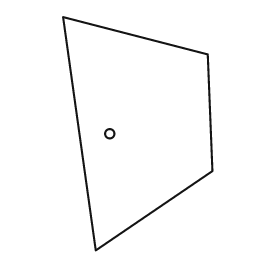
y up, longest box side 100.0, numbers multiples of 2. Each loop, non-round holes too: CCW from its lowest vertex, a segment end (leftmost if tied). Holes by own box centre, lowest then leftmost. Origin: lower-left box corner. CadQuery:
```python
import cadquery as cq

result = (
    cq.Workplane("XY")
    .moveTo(14.0, 0.0)
    .lineTo(64.0, 34.0)
    .lineTo(62.0, 84.0)
    .lineTo(0.0, 100.0)
    .close()
    .moveTo(20.0, 50.0)
    .circle(2.0)
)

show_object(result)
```